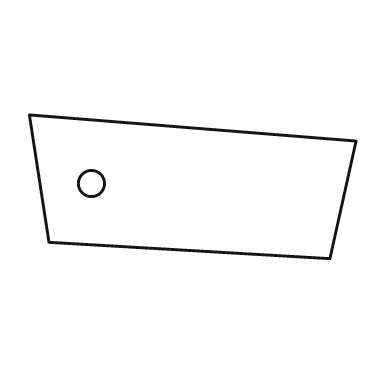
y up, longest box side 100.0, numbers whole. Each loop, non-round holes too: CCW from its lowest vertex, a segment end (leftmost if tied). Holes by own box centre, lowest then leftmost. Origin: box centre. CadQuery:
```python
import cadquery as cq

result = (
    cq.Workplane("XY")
    .moveTo(42.0, -22.0)
    .lineTo(50.0, 14.0)
    .lineTo(-50.0, 22.0)
    .lineTo(-44.0, -17.0)
    .close()
    .moveTo(-31.0, 1.0)
    .circle(4.0)
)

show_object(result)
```